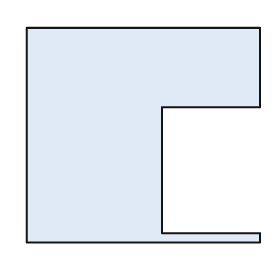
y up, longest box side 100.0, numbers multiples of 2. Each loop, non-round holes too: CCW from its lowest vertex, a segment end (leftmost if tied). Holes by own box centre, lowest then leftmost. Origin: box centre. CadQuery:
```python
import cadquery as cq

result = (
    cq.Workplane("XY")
    .moveTo(-50.0, -46.0)
    .lineTo(50.0, -46.0)
    .lineTo(50.0, -42.0)
    .lineTo(8.0, -42.0)
    .lineTo(8.0, 12.0)
    .lineTo(50.0, 12.0)
    .lineTo(50.0, 46.0)
    .lineTo(-50.0, 46.0)
    .close()
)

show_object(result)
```